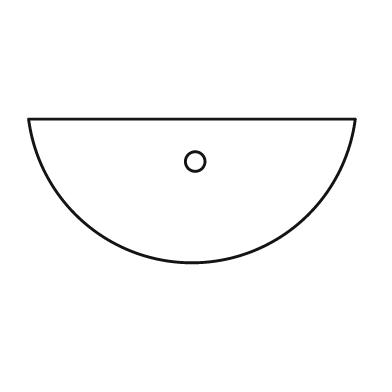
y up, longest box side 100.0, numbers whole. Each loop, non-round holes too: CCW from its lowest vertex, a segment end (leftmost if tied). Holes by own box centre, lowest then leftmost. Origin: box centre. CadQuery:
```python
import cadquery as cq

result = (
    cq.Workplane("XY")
    .moveTo(-50.0, 22.0)
    .threePointArc((0.0, -22.0), (50.0, 22.0))
    .close()
    .moveTo(1.0, 9.0)
    .circle(3.0)
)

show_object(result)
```